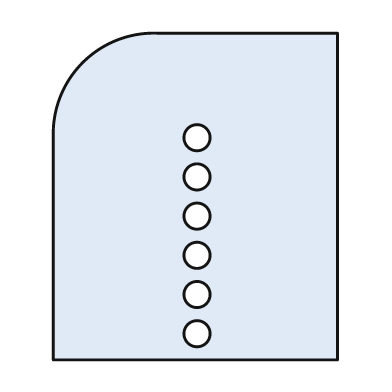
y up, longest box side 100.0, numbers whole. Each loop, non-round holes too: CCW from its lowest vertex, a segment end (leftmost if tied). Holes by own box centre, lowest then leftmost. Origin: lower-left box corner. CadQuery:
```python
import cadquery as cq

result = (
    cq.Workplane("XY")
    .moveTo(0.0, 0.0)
    .lineTo(87.0, 0.0)
    .lineTo(87.0, 100.0)
    .lineTo(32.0, 100.0)
    .threePointArc((9.0, 91.0), (0.0, 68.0))
    .close()
    .moveTo(44.0, 8.0)
    .circle(4.0)
    .moveTo(44.0, 20.0)
    .circle(4.0)
    .moveTo(44.0, 32.0)
    .circle(4.0)
    .moveTo(44.0, 44.0)
    .circle(4.0)
    .moveTo(44.0, 56.0)
    .circle(4.0)
    .moveTo(44.0, 68.0)
    .circle(4.0)
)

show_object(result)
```